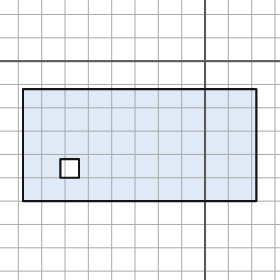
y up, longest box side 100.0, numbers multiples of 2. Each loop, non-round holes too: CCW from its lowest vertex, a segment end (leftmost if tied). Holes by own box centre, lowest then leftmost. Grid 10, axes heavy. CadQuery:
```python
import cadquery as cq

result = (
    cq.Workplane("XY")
    .moveTo(-78.0, -60.0)
    .lineTo(22.0, -60.0)
    .lineTo(22.0, -12.0)
    .lineTo(-78.0, -12.0)
    .close()
    .moveTo(-62.0, -50.0)
    .lineTo(-54.0, -50.0)
    .lineTo(-54.0, -42.0)
    .lineTo(-62.0, -42.0)
    .close()
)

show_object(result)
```